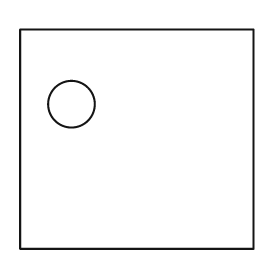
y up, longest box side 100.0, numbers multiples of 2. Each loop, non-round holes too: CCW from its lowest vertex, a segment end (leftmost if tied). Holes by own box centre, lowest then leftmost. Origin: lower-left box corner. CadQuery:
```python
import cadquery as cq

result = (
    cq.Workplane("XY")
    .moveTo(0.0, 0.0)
    .lineTo(100.0, 0.0)
    .lineTo(100.0, 94.0)
    .lineTo(0.0, 94.0)
    .close()
    .moveTo(22.0, 62.0)
    .circle(10.0)
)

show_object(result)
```